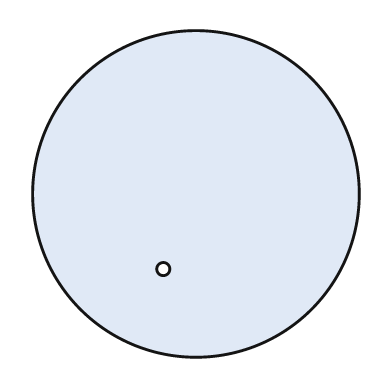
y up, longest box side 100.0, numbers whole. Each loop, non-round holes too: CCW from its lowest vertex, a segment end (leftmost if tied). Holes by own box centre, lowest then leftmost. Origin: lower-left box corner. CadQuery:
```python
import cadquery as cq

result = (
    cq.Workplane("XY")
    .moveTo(50.0, 50.0)
    .circle(50.0)
    .moveTo(40.0, 27.0)
    .circle(2.0)
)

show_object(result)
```